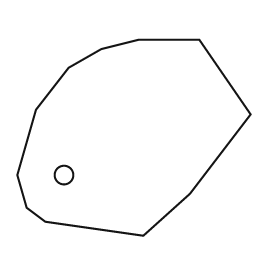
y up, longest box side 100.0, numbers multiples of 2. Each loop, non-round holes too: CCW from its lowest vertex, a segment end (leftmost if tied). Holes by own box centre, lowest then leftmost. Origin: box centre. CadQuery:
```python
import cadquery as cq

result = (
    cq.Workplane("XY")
    .moveTo(4.0, -42.0)
    .lineTo(24.0, -24.0)
    .lineTo(50.0, 10.0)
    .lineTo(28.0, 42.0)
    .lineTo(2.0, 42.0)
    .lineTo(-14.0, 38.0)
    .lineTo(-28.0, 30.0)
    .lineTo(-42.0, 12.0)
    .lineTo(-50.0, -16.0)
    .lineTo(-46.0, -30.0)
    .lineTo(-38.0, -36.0)
    .close()
    .moveTo(-30.0, -16.0)
    .circle(4.0)
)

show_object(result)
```